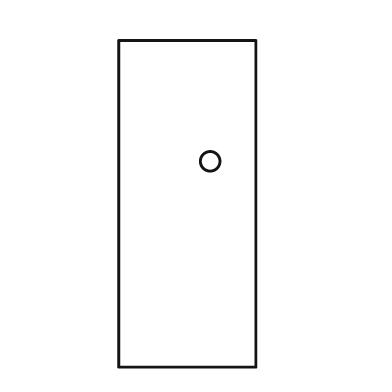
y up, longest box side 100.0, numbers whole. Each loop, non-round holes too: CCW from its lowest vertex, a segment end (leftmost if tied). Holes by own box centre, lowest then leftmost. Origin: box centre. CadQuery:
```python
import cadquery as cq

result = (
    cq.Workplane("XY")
    .moveTo(-21.0, -50.0)
    .lineTo(21.0, -50.0)
    .lineTo(21.0, 50.0)
    .lineTo(-21.0, 50.0)
    .close()
    .moveTo(7.0, 13.0)
    .circle(3.0)
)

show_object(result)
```